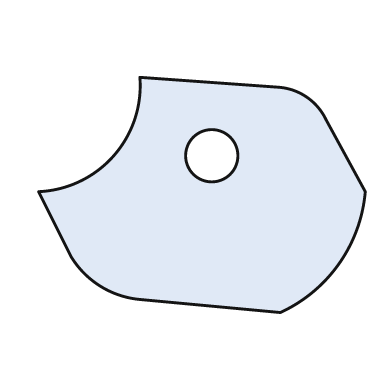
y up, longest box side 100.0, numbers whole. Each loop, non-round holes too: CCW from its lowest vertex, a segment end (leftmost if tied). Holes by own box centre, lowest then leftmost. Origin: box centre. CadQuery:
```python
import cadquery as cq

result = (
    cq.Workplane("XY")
    .moveTo(24.0, -36.0)
    .threePointArc((42.0, -21.0), (50.0, 1.0))
    .lineTo(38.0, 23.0)
    .threePointArc((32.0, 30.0), (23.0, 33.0))
    .lineTo(-19.0, 36.0)
    .threePointArc((-27.0, 12.0), (-50.0, 1.0))
    .lineTo(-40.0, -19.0)
    .threePointArc((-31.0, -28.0), (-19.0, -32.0))
    .close()
    .moveTo(3.0, 12.0)
    .circle(8.0)
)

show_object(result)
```